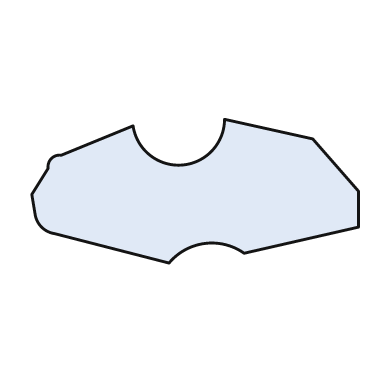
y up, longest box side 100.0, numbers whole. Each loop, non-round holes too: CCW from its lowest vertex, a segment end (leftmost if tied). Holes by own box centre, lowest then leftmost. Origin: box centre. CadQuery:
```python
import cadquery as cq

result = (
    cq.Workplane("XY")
    .moveTo(-8.0, -22.0)
    .threePointArc((3.0, -16.0), (15.0, -19.0))
    .lineTo(50.0, -11.0)
    .lineTo(50.0, 0.0)
    .lineTo(36.0, 16.0)
    .lineTo(9.0, 22.0)
    .threePointArc((-4.0, 8.0), (-19.0, 20.0))
    .lineTo(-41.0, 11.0)
    .threePointArc((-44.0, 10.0), (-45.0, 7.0))
    .lineTo(-50.0, -1.0)
    .lineTo(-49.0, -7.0)
    .threePointArc((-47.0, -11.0), (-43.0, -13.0))
    .close()
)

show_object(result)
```